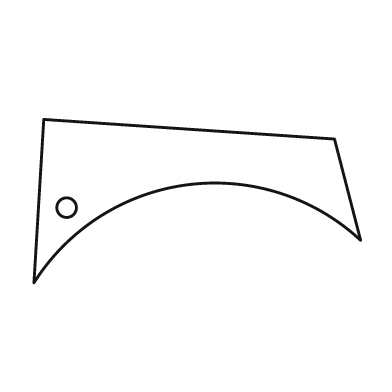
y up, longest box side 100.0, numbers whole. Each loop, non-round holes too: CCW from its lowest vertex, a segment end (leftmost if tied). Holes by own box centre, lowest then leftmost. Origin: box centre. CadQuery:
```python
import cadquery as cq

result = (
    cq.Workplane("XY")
    .moveTo(-50.0, -25.0)
    .threePointArc((-3.0, 5.0), (50.0, -12.0))
    .lineTo(42.0, 19.0)
    .lineTo(-47.0, 25.0)
    .close()
    .moveTo(-40.0, -2.0)
    .circle(3.0)
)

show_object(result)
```